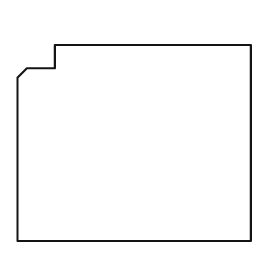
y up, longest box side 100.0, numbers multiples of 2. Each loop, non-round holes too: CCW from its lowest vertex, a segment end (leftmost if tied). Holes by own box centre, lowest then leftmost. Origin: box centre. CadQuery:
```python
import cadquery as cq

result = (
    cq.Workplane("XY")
    .moveTo(-50.0, -42.0)
    .lineTo(50.0, -42.0)
    .lineTo(50.0, 42.0)
    .lineTo(-34.0, 42.0)
    .lineTo(-34.0, 32.0)
    .lineTo(-46.0, 32.0)
    .lineTo(-50.0, 28.0)
    .close()
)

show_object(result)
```